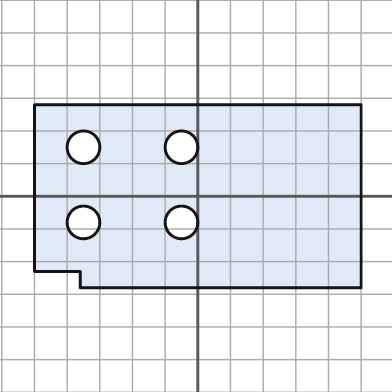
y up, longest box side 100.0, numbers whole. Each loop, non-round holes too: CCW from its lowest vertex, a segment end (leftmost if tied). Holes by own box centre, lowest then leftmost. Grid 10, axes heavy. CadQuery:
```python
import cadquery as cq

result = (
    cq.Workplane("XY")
    .moveTo(-36.0, -28.0)
    .lineTo(50.0, -28.0)
    .lineTo(50.0, 28.0)
    .lineTo(-50.0, 28.0)
    .lineTo(-50.0, -23.0)
    .lineTo(-36.0, -23.0)
    .close()
    .moveTo(-35.0, -8.0)
    .circle(5.0)
    .moveTo(-5.0, -8.0)
    .circle(5.0)
    .moveTo(-35.0, 15.0)
    .circle(5.0)
    .moveTo(-5.0, 15.0)
    .circle(5.0)
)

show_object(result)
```